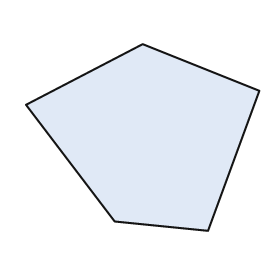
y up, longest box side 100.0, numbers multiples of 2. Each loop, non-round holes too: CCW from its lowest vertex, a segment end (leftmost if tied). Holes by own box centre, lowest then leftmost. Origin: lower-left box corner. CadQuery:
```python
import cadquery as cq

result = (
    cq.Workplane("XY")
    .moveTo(78.0, 0.0)
    .lineTo(100.0, 60.0)
    .lineTo(50.0, 80.0)
    .lineTo(0.0, 54.0)
    .lineTo(38.0, 4.0)
    .close()
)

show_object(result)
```